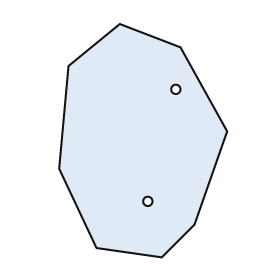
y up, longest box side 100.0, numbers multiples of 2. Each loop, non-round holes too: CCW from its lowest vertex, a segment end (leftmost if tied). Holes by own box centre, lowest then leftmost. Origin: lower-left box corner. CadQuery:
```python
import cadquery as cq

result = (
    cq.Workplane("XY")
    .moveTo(44.0, 0.0)
    .lineTo(58.0, 14.0)
    .lineTo(72.0, 54.0)
    .lineTo(52.0, 90.0)
    .lineTo(26.0, 100.0)
    .lineTo(4.0, 82.0)
    .lineTo(0.0, 38.0)
    .lineTo(16.0, 4.0)
    .close()
    .moveTo(38.0, 24.0)
    .circle(2.0)
    .moveTo(50.0, 72.0)
    .circle(2.0)
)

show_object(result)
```